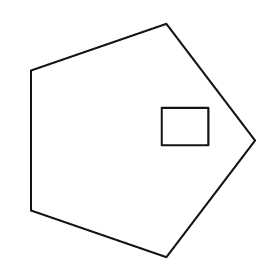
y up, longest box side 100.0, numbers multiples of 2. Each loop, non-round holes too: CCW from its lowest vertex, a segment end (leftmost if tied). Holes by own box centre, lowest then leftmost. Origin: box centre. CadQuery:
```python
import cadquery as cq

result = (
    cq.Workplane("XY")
    .moveTo(10.0, -50.0)
    .lineTo(48.0, 0.0)
    .lineTo(10.0, 50.0)
    .lineTo(-48.0, 30.0)
    .lineTo(-48.0, -30.0)
    .close()
    .moveTo(8.0, -2.0)
    .lineTo(28.0, -2.0)
    .lineTo(28.0, 14.0)
    .lineTo(8.0, 14.0)
    .close()
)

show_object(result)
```